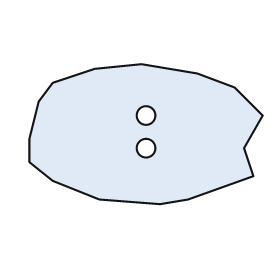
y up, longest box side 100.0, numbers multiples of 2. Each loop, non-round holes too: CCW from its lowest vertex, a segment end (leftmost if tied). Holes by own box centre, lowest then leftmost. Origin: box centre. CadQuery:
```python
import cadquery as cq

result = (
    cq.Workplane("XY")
    .moveTo(6.0, -30.0)
    .lineTo(18.0, -28.0)
    .lineTo(46.0, -18.0)
    .lineTo(42.0, -6.0)
    .lineTo(50.0, 8.0)
    .lineTo(38.0, 20.0)
    .lineTo(22.0, 26.0)
    .lineTo(-2.0, 30.0)
    .lineTo(-22.0, 28.0)
    .lineTo(-40.0, 22.0)
    .lineTo(-46.0, 14.0)
    .lineTo(-50.0, -2.0)
    .lineTo(-50.0, -12.0)
    .lineTo(-40.0, -20.0)
    .lineTo(-20.0, -28.0)
    .close()
    .moveTo(0.0, -6.0)
    .circle(4.0)
    .moveTo(0.0, 8.0)
    .circle(4.0)
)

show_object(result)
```